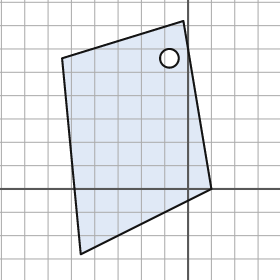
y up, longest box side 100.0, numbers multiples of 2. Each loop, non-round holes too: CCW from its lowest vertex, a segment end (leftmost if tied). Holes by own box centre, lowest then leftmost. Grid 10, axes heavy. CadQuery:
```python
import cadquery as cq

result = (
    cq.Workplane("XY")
    .moveTo(-46.0, -28.0)
    .lineTo(10.0, 0.0)
    .lineTo(-2.0, 72.0)
    .lineTo(-54.0, 56.0)
    .close()
    .moveTo(-8.0, 56.0)
    .circle(4.0)
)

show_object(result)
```